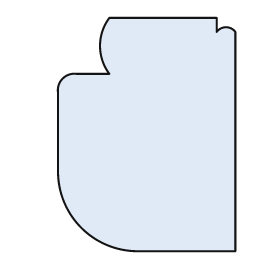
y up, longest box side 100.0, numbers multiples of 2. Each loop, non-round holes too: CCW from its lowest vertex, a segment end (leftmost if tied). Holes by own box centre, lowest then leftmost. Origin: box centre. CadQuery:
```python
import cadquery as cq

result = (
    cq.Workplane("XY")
    .moveTo(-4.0, -50.0)
    .lineTo(38.0, -50.0)
    .lineTo(38.0, 44.0)
    .threePointArc((34.0, 46.0), (30.0, 44.0))
    .lineTo(30.0, 50.0)
    .lineTo(-16.0, 50.0)
    .threePointArc((-20.0, 38.0), (-16.0, 26.0))
    .lineTo(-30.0, 26.0)
    .threePointArc((-36.0, 24.0), (-38.0, 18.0))
    .lineTo(-38.0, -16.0)
    .threePointArc((-28.0, -40.0), (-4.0, -50.0))
    .close()
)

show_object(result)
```